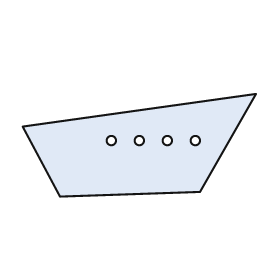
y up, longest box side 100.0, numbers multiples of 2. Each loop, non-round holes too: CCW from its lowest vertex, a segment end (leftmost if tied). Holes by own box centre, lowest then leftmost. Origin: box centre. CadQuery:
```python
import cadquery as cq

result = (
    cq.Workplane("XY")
    .moveTo(-34.0, -22.0)
    .lineTo(26.0, -20.0)
    .lineTo(50.0, 22.0)
    .lineTo(-50.0, 8.0)
    .close()
    .moveTo(-12.0, 2.0)
    .circle(2.0)
    .moveTo(0.0, 2.0)
    .circle(2.0)
    .moveTo(12.0, 2.0)
    .circle(2.0)
    .moveTo(24.0, 2.0)
    .circle(2.0)
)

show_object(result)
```